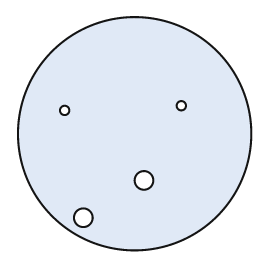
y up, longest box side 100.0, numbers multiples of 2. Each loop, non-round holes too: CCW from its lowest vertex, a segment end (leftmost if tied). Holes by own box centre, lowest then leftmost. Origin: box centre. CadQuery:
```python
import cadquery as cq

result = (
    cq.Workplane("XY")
    .moveTo(0.0, 0.0)
    .circle(50.0)
    .moveTo(-22.0, -36.0)
    .circle(4.0)
    .moveTo(4.0, -20.0)
    .circle(4.0)
    .moveTo(-30.0, 10.0)
    .circle(2.0)
    .moveTo(20.0, 12.0)
    .circle(2.0)
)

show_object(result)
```